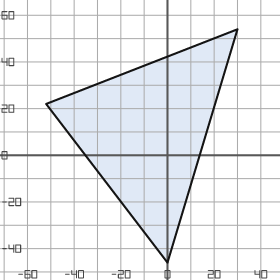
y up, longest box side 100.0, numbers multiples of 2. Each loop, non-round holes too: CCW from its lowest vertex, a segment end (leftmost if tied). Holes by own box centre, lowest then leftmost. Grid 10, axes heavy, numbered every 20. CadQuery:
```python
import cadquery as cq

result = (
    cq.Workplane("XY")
    .moveTo(0.0, -46.0)
    .lineTo(30.0, 54.0)
    .lineTo(-52.0, 22.0)
    .close()
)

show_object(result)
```